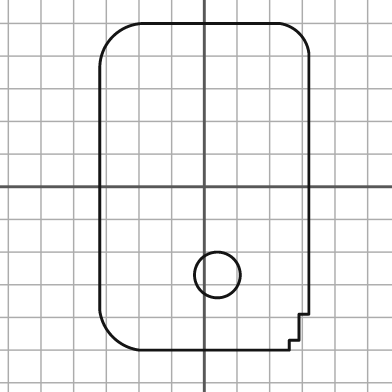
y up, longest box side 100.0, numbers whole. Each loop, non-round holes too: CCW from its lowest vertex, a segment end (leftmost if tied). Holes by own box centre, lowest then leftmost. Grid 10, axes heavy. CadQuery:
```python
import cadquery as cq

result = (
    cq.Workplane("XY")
    .moveTo(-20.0, -50.0)
    .lineTo(26.0, -50.0)
    .lineTo(26.0, -47.0)
    .lineTo(29.0, -47.0)
    .lineTo(29.0, -39.0)
    .lineTo(32.0, -39.0)
    .lineTo(32.0, 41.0)
    .threePointArc((29.0, 47.0), (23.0, 50.0))
    .lineTo(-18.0, 50.0)
    .threePointArc((-28.0, 46.0), (-32.0, 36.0))
    .lineTo(-32.0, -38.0)
    .threePointArc((-28.0, -46.0), (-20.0, -50.0))
    .close()
    .moveTo(4.0, -27.0)
    .circle(7.0)
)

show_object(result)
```